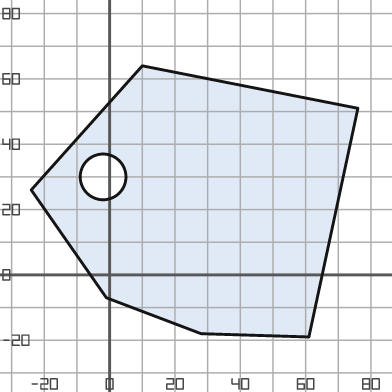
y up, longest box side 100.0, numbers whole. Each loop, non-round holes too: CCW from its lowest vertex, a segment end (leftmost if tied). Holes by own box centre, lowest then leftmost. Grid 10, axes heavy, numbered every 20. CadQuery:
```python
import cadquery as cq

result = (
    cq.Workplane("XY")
    .moveTo(61.0, -19.0)
    .lineTo(76.0, 51.0)
    .lineTo(10.0, 64.0)
    .lineTo(-24.0, 26.0)
    .lineTo(-1.0, -7.0)
    .lineTo(28.0, -18.0)
    .close()
    .moveTo(-2.0, 30.0)
    .circle(7.0)
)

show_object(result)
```